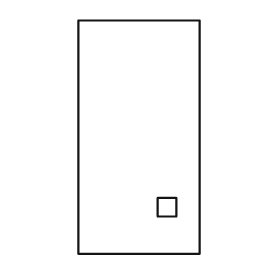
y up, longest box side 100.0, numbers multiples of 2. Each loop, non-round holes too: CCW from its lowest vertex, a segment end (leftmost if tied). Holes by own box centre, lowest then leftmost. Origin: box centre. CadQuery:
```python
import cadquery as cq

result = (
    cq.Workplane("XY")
    .moveTo(-26.0, -50.0)
    .lineTo(26.0, -50.0)
    .lineTo(26.0, 50.0)
    .lineTo(-26.0, 50.0)
    .close()
    .moveTo(8.0, -34.0)
    .lineTo(16.0, -34.0)
    .lineTo(16.0, -26.0)
    .lineTo(8.0, -26.0)
    .close()
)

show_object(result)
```